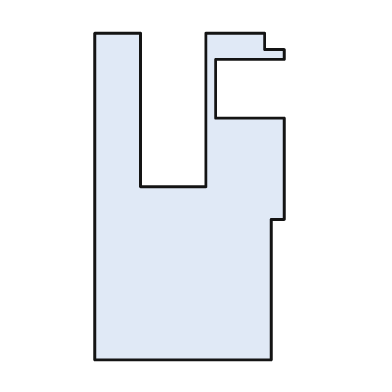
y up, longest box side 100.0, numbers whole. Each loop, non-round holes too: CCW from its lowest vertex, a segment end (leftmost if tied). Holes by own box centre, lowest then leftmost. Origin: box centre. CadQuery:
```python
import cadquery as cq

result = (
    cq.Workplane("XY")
    .moveTo(-29.0, -50.0)
    .lineTo(25.0, -50.0)
    .lineTo(25.0, -7.0)
    .lineTo(29.0, -7.0)
    .lineTo(29.0, 24.0)
    .lineTo(8.0, 24.0)
    .lineTo(8.0, 42.0)
    .lineTo(29.0, 42.0)
    .lineTo(29.0, 45.0)
    .lineTo(23.0, 45.0)
    .lineTo(23.0, 50.0)
    .lineTo(5.0, 50.0)
    .lineTo(5.0, 3.0)
    .lineTo(-15.0, 3.0)
    .lineTo(-15.0, 50.0)
    .lineTo(-29.0, 50.0)
    .close()
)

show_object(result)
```